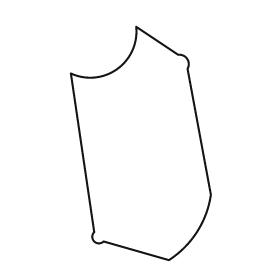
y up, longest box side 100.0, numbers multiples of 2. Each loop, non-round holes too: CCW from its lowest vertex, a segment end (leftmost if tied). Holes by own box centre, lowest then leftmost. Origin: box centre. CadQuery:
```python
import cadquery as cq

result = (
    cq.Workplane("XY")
    .moveTo(12.0, -50.0)
    .threePointArc((24.0, -38.0), (30.0, -22.0))
    .lineTo(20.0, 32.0)
    .threePointArc((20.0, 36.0), (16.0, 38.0))
    .lineTo(-2.0, 50.0)
    .threePointArc((-10.0, 32.0), (-30.0, 30.0))
    .lineTo(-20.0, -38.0)
    .threePointArc((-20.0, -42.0), (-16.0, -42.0))
    .close()
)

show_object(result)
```